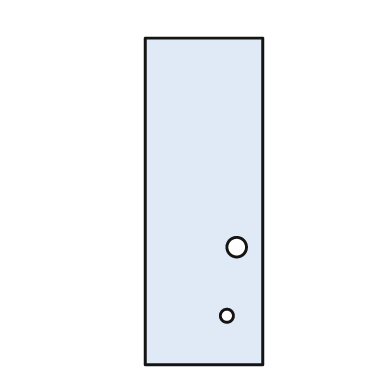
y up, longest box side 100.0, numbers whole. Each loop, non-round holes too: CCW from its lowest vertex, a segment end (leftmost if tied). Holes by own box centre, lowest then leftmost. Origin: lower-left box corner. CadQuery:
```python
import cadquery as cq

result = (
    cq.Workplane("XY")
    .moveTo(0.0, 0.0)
    .lineTo(36.0, 0.0)
    .lineTo(36.0, 100.0)
    .lineTo(0.0, 100.0)
    .close()
    .moveTo(25.0, 15.0)
    .circle(2.0)
    .moveTo(28.0, 36.0)
    .circle(3.0)
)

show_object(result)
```